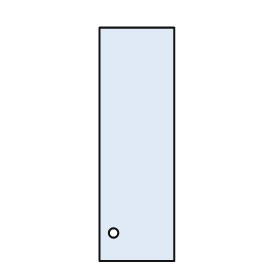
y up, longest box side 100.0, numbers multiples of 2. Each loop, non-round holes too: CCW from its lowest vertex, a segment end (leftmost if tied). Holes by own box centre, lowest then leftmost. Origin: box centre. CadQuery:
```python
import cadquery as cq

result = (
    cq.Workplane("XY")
    .moveTo(-16.0, -50.0)
    .lineTo(16.0, -50.0)
    .lineTo(16.0, 50.0)
    .lineTo(-16.0, 50.0)
    .close()
    .moveTo(-10.0, -38.0)
    .circle(2.0)
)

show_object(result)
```